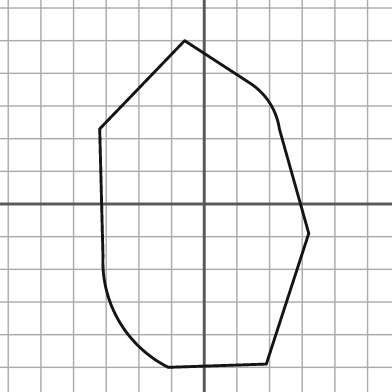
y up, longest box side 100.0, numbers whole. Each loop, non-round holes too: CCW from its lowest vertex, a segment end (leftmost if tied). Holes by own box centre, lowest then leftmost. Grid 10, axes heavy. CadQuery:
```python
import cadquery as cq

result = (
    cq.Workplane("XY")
    .moveTo(-11.0, -50.0)
    .lineTo(19.0, -49.0)
    .lineTo(32.0, -9.0)
    .lineTo(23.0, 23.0)
    .threePointArc((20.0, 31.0), (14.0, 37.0))
    .lineTo(-6.0, 50.0)
    .lineTo(-32.0, 23.0)
    .lineTo(-31.0, -16.0)
    .threePointArc((-26.0, -36.0), (-11.0, -50.0))
    .close()
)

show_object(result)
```